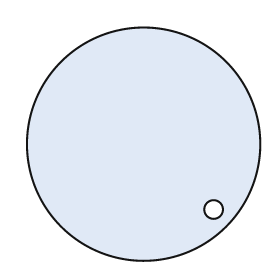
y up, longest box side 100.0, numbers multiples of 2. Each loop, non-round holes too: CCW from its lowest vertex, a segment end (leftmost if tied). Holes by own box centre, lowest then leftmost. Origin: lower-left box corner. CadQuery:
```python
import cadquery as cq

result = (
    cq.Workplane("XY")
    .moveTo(50.0, 50.0)
    .circle(50.0)
    .moveTo(80.0, 22.0)
    .circle(4.0)
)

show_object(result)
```